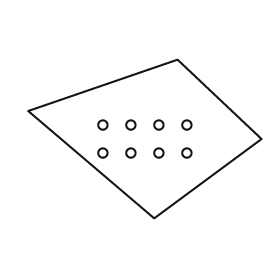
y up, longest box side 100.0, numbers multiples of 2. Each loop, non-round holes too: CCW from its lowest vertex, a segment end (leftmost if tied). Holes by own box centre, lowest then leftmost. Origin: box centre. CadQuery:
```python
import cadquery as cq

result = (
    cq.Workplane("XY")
    .moveTo(4.0, -34.0)
    .lineTo(50.0, 0.0)
    .lineTo(14.0, 34.0)
    .lineTo(-50.0, 12.0)
    .close()
    .moveTo(-18.0, -6.0)
    .circle(2.0)
    .moveTo(-6.0, -6.0)
    .circle(2.0)
    .moveTo(6.0, -6.0)
    .circle(2.0)
    .moveTo(18.0, -6.0)
    .circle(2.0)
    .moveTo(-18.0, 6.0)
    .circle(2.0)
    .moveTo(-6.0, 6.0)
    .circle(2.0)
    .moveTo(6.0, 6.0)
    .circle(2.0)
    .moveTo(18.0, 6.0)
    .circle(2.0)
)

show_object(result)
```